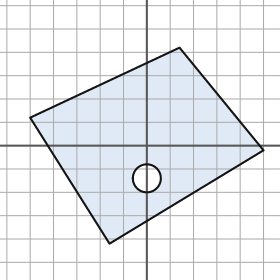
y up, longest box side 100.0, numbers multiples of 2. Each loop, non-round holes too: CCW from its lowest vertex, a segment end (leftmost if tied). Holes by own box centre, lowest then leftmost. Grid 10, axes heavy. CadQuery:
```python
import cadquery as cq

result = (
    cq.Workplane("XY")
    .moveTo(-16.0, -42.0)
    .lineTo(50.0, -2.0)
    .lineTo(14.0, 42.0)
    .lineTo(-50.0, 12.0)
    .close()
    .moveTo(0.0, -14.0)
    .circle(6.0)
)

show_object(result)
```